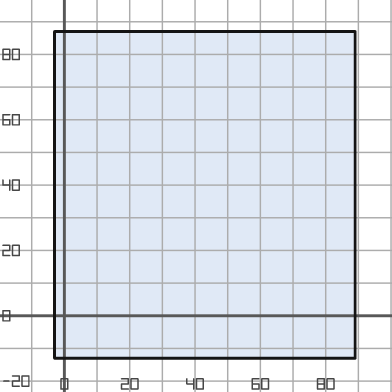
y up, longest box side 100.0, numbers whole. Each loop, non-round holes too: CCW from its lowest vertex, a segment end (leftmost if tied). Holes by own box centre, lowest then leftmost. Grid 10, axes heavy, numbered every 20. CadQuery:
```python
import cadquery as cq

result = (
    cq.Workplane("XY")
    .moveTo(-3.0, -13.0)
    .lineTo(89.0, -13.0)
    .lineTo(89.0, 87.0)
    .lineTo(-3.0, 87.0)
    .close()
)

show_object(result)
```